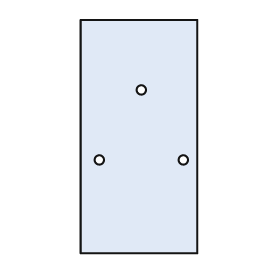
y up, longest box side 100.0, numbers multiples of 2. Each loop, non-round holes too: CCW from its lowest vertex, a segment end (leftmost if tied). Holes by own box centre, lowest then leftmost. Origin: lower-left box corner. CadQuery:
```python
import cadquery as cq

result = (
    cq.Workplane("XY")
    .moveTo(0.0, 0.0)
    .lineTo(50.0, 0.0)
    .lineTo(50.0, 100.0)
    .lineTo(0.0, 100.0)
    .close()
    .moveTo(8.0, 40.0)
    .circle(2.0)
    .moveTo(44.0, 40.0)
    .circle(2.0)
    .moveTo(26.0, 70.0)
    .circle(2.0)
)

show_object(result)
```